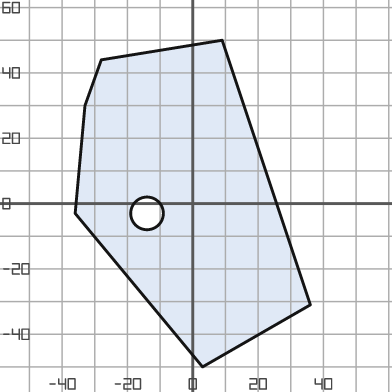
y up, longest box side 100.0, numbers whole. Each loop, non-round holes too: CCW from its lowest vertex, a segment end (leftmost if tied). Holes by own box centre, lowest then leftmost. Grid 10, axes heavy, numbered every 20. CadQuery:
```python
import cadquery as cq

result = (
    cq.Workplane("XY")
    .moveTo(3.0, -50.0)
    .lineTo(36.0, -31.0)
    .lineTo(9.0, 50.0)
    .lineTo(-28.0, 44.0)
    .lineTo(-33.0, 30.0)
    .lineTo(-36.0, -3.0)
    .close()
    .moveTo(-14.0, -3.0)
    .circle(5.0)
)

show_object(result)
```